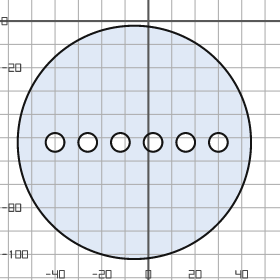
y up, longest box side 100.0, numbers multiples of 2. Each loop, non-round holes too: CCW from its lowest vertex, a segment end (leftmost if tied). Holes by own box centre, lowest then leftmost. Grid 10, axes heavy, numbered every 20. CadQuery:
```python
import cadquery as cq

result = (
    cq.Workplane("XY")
    .moveTo(-6.0, -52.0)
    .circle(50.0)
    .moveTo(-40.0, -52.0)
    .circle(4.0)
    .moveTo(-26.0, -52.0)
    .circle(4.0)
    .moveTo(-12.0, -52.0)
    .circle(4.0)
    .moveTo(2.0, -52.0)
    .circle(4.0)
    .moveTo(16.0, -52.0)
    .circle(4.0)
    .moveTo(30.0, -52.0)
    .circle(4.0)
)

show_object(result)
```